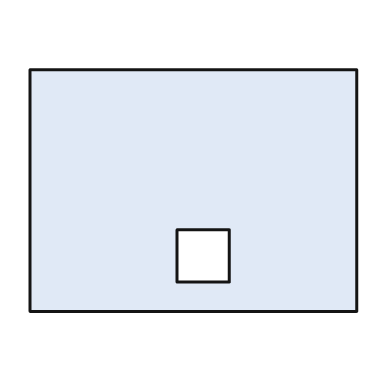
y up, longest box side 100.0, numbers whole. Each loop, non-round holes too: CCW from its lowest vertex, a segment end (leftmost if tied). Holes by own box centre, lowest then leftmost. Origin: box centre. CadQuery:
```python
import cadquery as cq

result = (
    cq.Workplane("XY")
    .moveTo(-50.0, -37.0)
    .lineTo(50.0, -37.0)
    .lineTo(50.0, 37.0)
    .lineTo(-50.0, 37.0)
    .close()
    .moveTo(-5.0, -28.0)
    .lineTo(11.0, -28.0)
    .lineTo(11.0, -12.0)
    .lineTo(-5.0, -12.0)
    .close()
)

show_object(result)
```